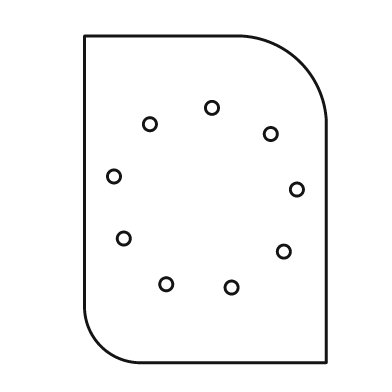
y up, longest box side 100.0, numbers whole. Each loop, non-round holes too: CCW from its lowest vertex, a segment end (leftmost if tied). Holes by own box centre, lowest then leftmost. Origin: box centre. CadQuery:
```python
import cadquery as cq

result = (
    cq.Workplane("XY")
    .moveTo(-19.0, -50.0)
    .lineTo(37.0, -50.0)
    .lineTo(37.0, 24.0)
    .threePointArc((29.0, 42.0), (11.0, 50.0))
    .lineTo(-37.0, 50.0)
    .lineTo(-37.0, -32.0)
    .threePointArc((-32.0, -45.0), (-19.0, -50.0))
    .close()
    .moveTo(8.0, -27.0)
    .circle(2.0)
    .moveTo(-12.0, -26.0)
    .circle(2.0)
    .moveTo(24.0, -16.0)
    .circle(2.0)
    .moveTo(-25.0, -12.0)
    .circle(2.0)
    .moveTo(28.0, 3.0)
    .circle(2.0)
    .moveTo(-28.0, 7.0)
    .circle(2.0)
    .moveTo(20.0, 20.0)
    .circle(2.0)
    .moveTo(-17.0, 23.0)
    .circle(2.0)
    .moveTo(2.0, 28.0)
    .circle(2.0)
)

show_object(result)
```